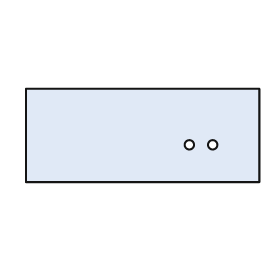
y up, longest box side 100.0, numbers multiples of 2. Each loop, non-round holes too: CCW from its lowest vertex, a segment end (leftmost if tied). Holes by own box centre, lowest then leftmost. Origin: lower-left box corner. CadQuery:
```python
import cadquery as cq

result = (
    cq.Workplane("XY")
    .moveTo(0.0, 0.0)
    .lineTo(100.0, 0.0)
    .lineTo(100.0, 40.0)
    .lineTo(0.0, 40.0)
    .close()
    .moveTo(70.0, 16.0)
    .circle(2.0)
    .moveTo(80.0, 16.0)
    .circle(2.0)
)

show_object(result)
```